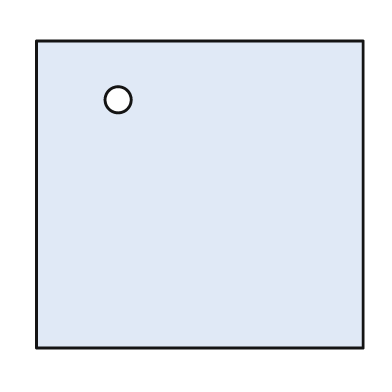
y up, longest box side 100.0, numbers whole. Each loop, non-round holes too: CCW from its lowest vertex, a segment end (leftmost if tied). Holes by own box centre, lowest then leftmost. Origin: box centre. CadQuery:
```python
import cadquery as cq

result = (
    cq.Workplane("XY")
    .moveTo(-50.0, -47.0)
    .lineTo(50.0, -47.0)
    .lineTo(50.0, 47.0)
    .lineTo(-50.0, 47.0)
    .close()
    .moveTo(-25.0, 29.0)
    .circle(4.0)
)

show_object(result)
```